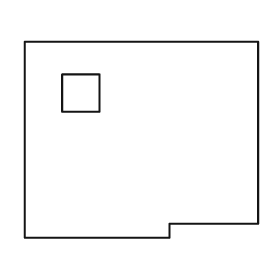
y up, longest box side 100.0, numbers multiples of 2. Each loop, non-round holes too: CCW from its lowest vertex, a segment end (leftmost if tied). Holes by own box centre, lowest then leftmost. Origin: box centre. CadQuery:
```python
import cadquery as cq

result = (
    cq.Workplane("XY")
    .moveTo(-50.0, -42.0)
    .lineTo(12.0, -42.0)
    .lineTo(12.0, -36.0)
    .lineTo(50.0, -36.0)
    .lineTo(50.0, 42.0)
    .lineTo(-50.0, 42.0)
    .close()
    .moveTo(-34.0, 12.0)
    .lineTo(-18.0, 12.0)
    .lineTo(-18.0, 28.0)
    .lineTo(-34.0, 28.0)
    .close()
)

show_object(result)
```